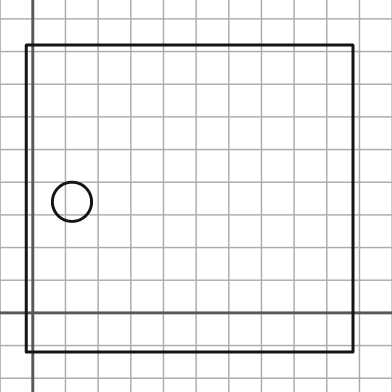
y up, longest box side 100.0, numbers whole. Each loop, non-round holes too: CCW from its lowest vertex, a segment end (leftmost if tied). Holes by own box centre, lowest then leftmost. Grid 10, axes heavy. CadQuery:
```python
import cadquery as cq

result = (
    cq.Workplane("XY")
    .moveTo(-2.0, -12.0)
    .lineTo(98.0, -12.0)
    .lineTo(98.0, 82.0)
    .lineTo(-2.0, 82.0)
    .close()
    .moveTo(12.0, 34.0)
    .circle(6.0)
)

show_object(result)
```